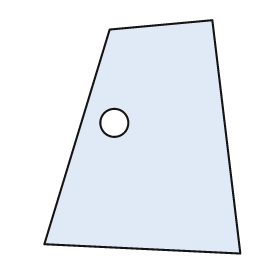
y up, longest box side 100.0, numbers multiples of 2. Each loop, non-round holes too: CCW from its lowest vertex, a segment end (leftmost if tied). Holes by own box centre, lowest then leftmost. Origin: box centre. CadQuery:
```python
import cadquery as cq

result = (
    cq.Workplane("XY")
    .moveTo(42.0, -50.0)
    .lineTo(30.0, 50.0)
    .lineTo(-14.0, 46.0)
    .lineTo(-42.0, -46.0)
    .close()
    .moveTo(-12.0, 6.0)
    .circle(6.0)
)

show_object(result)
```